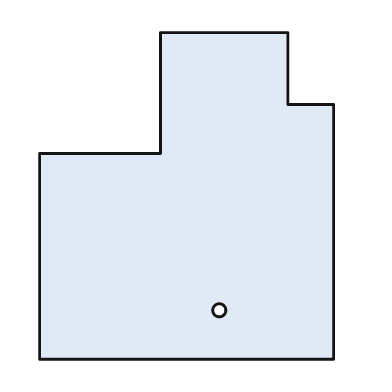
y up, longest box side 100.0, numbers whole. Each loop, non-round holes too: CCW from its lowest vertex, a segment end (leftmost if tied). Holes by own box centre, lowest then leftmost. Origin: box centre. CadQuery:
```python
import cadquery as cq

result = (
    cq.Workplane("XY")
    .moveTo(-45.0, -50.0)
    .lineTo(45.0, -50.0)
    .lineTo(45.0, 28.0)
    .lineTo(31.0, 28.0)
    .lineTo(31.0, 50.0)
    .lineTo(-8.0, 50.0)
    .lineTo(-8.0, 13.0)
    .lineTo(-45.0, 13.0)
    .close()
    .moveTo(10.0, -35.0)
    .circle(2.0)
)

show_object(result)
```